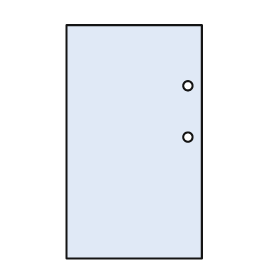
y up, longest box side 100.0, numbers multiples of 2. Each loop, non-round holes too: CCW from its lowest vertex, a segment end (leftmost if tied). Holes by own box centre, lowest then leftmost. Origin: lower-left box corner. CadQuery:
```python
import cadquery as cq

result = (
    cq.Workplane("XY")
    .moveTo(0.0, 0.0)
    .lineTo(58.0, 0.0)
    .lineTo(58.0, 100.0)
    .lineTo(0.0, 100.0)
    .close()
    .moveTo(52.0, 52.0)
    .circle(2.0)
    .moveTo(52.0, 74.0)
    .circle(2.0)
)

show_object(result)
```